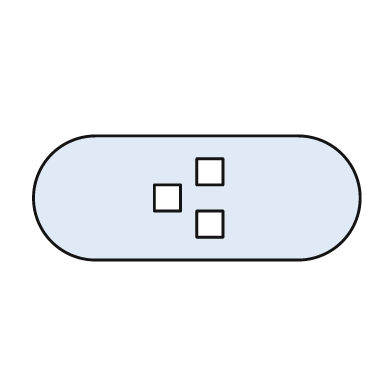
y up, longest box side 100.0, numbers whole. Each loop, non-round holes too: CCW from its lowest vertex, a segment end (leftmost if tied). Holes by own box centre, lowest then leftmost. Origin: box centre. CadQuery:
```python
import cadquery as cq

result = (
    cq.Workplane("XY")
    .moveTo(-31.0, -19.0)
    .lineTo(31.0, -19.0)
    .threePointArc((50.0, 0.0), (31.0, 19.0))
    .lineTo(-31.0, 19.0)
    .threePointArc((-50.0, 0.0), (-31.0, -19.0))
    .close()
    .moveTo(0.0, -12.0)
    .lineTo(8.0, -12.0)
    .lineTo(8.0, -4.0)
    .lineTo(0.0, -4.0)
    .close()
    .moveTo(-13.0, -4.0)
    .lineTo(-5.0, -4.0)
    .lineTo(-5.0, 4.0)
    .lineTo(-13.0, 4.0)
    .close()
    .moveTo(0.0, 4.0)
    .lineTo(8.0, 4.0)
    .lineTo(8.0, 12.0)
    .lineTo(0.0, 12.0)
    .close()
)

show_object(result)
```